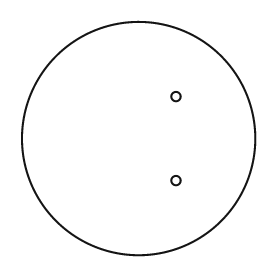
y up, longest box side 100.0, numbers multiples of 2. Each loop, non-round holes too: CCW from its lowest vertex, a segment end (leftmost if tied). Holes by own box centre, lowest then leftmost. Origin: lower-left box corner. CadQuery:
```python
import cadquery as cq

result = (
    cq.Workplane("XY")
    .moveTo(50.0, 50.0)
    .circle(50.0)
    .moveTo(66.0, 32.0)
    .circle(2.0)
    .moveTo(66.0, 68.0)
    .circle(2.0)
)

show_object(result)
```